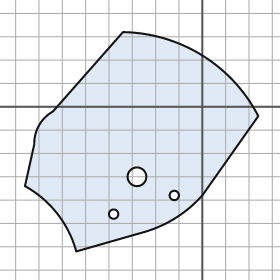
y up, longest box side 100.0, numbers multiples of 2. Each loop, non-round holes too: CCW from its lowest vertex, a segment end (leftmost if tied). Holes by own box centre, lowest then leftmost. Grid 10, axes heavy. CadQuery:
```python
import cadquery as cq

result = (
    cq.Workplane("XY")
    .moveTo(-54.0, -62.0)
    .lineTo(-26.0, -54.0)
    .threePointArc((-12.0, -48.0), (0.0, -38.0))
    .lineTo(24.0, -4.0)
    .threePointArc((0.0, 22.0), (-34.0, 32.0))
    .lineTo(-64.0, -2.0)
    .threePointArc((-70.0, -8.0), (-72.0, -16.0))
    .lineTo(-76.0, -34.0)
    .threePointArc((-62.0, -46.0), (-54.0, -62.0))
    .close()
    .moveTo(-38.0, -46.0)
    .circle(2.0)
    .moveTo(-12.0, -38.0)
    .circle(2.0)
    .moveTo(-28.0, -30.0)
    .circle(4.0)
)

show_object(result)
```